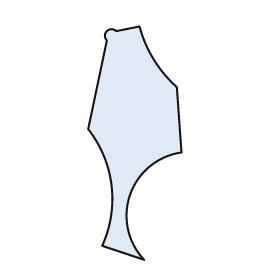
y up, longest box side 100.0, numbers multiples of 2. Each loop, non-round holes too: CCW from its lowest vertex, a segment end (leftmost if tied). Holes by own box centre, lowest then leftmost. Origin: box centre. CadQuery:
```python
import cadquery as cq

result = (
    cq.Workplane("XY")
    .moveTo(4.0, -50.0)
    .threePointArc((-2.0, -22.0), (20.0, -4.0))
    .lineTo(18.0, 24.0)
    .threePointArc((8.0, 36.0), (2.0, 50.0))
    .lineTo(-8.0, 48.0)
    .threePointArc((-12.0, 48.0), (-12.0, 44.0))
    .lineTo(-20.0, 6.0)
    .threePointArc((-10.0, -18.0), (-14.0, -44.0))
    .close()
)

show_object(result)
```